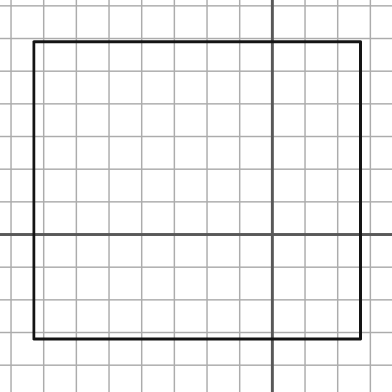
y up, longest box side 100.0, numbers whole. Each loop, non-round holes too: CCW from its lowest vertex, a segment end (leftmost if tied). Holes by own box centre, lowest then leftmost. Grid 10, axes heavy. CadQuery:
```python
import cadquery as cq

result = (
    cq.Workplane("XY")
    .moveTo(-73.0, -32.0)
    .lineTo(27.0, -32.0)
    .lineTo(27.0, 59.0)
    .lineTo(-73.0, 59.0)
    .close()
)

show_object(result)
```